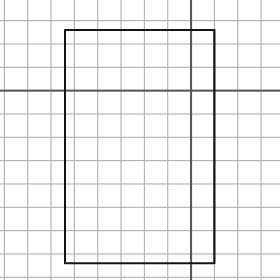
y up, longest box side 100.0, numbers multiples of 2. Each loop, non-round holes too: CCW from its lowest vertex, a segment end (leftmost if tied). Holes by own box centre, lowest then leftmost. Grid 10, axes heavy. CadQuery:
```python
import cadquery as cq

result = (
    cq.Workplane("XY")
    .moveTo(-54.0, -74.0)
    .lineTo(10.0, -74.0)
    .lineTo(10.0, 26.0)
    .lineTo(-54.0, 26.0)
    .close()
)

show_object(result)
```